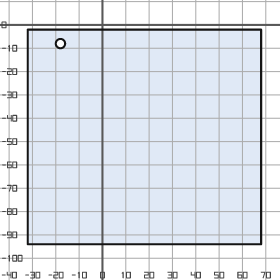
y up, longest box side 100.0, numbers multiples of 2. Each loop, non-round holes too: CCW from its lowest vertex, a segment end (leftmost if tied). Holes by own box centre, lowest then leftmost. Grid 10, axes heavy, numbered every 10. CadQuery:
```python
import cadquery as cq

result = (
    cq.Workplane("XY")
    .moveTo(-32.0, -94.0)
    .lineTo(68.0, -94.0)
    .lineTo(68.0, -2.0)
    .lineTo(-32.0, -2.0)
    .close()
    .moveTo(-18.0, -8.0)
    .circle(2.0)
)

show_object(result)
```